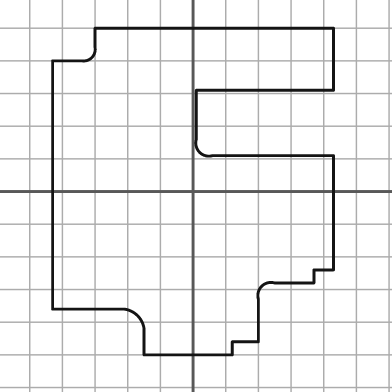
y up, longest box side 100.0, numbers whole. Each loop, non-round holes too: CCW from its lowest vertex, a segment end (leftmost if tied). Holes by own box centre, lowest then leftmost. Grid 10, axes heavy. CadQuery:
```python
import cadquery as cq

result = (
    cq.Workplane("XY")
    .moveTo(-15.0, -50.0)
    .lineTo(12.0, -50.0)
    .lineTo(12.0, -46.0)
    .lineTo(20.0, -46.0)
    .lineTo(20.0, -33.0)
    .threePointArc((21.0, -29.0), (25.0, -28.0))
    .lineTo(37.0, -28.0)
    .lineTo(37.0, -24.0)
    .lineTo(43.0, -24.0)
    .lineTo(43.0, 11.0)
    .lineTo(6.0, 11.0)
    .threePointArc((2.0, 12.0), (1.0, 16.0))
    .lineTo(1.0, 31.0)
    .lineTo(43.0, 31.0)
    .lineTo(43.0, 50.0)
    .lineTo(-30.0, 50.0)
    .lineTo(-30.0, 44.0)
    .threePointArc((-31.0, 41.0), (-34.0, 40.0))
    .lineTo(-43.0, 40.0)
    .lineTo(-43.0, -36.0)
    .lineTo(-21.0, -36.0)
    .threePointArc((-17.0, -38.0), (-15.0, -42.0))
    .close()
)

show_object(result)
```